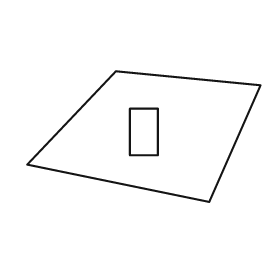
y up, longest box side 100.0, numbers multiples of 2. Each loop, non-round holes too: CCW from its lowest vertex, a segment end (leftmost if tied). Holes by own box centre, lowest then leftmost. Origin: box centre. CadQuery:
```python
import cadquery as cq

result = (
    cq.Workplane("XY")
    .moveTo(28.0, -28.0)
    .lineTo(50.0, 22.0)
    .lineTo(-12.0, 28.0)
    .lineTo(-50.0, -12.0)
    .close()
    .moveTo(-6.0, -8.0)
    .lineTo(6.0, -8.0)
    .lineTo(6.0, 12.0)
    .lineTo(-6.0, 12.0)
    .close()
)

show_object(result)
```